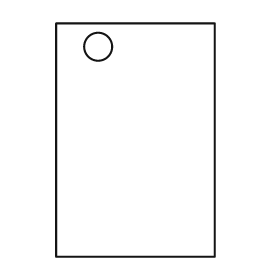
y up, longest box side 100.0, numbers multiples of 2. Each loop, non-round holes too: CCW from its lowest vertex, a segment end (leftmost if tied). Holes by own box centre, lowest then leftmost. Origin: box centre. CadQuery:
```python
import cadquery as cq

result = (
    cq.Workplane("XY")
    .moveTo(-34.0, -50.0)
    .lineTo(34.0, -50.0)
    .lineTo(34.0, 50.0)
    .lineTo(-34.0, 50.0)
    .close()
    .moveTo(-16.0, 40.0)
    .circle(6.0)
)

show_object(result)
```